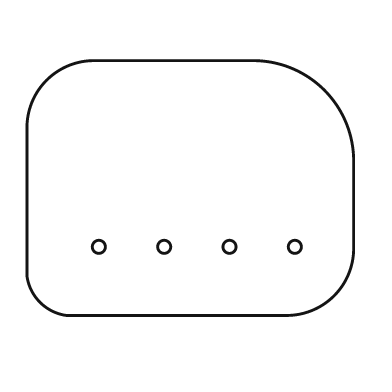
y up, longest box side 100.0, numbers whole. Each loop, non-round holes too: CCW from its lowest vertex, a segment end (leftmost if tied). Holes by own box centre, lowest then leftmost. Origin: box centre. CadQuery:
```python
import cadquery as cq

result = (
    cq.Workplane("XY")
    .moveTo(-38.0, -39.0)
    .lineTo(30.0, -39.0)
    .threePointArc((44.0, -33.0), (50.0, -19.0))
    .lineTo(50.0, 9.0)
    .threePointArc((41.0, 30.0), (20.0, 39.0))
    .lineTo(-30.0, 39.0)
    .threePointArc((-44.0, 33.0), (-50.0, 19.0))
    .lineTo(-50.0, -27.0)
    .threePointArc((-46.0, -35.0), (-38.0, -39.0))
    .close()
    .moveTo(-28.0, -18.0)
    .circle(2.0)
    .moveTo(-8.0, -18.0)
    .circle(2.0)
    .moveTo(12.0, -18.0)
    .circle(2.0)
    .moveTo(32.0, -18.0)
    .circle(2.0)
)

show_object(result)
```